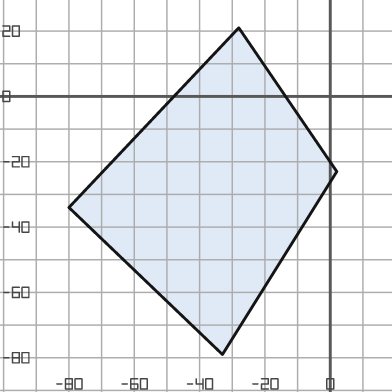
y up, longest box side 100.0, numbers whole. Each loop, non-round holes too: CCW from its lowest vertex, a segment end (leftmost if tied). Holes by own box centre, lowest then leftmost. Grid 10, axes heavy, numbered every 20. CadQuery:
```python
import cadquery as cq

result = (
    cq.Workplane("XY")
    .moveTo(-33.0, -79.0)
    .lineTo(2.0, -23.0)
    .lineTo(-28.0, 21.0)
    .lineTo(-80.0, -34.0)
    .close()
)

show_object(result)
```